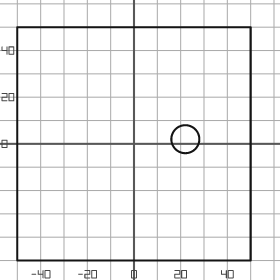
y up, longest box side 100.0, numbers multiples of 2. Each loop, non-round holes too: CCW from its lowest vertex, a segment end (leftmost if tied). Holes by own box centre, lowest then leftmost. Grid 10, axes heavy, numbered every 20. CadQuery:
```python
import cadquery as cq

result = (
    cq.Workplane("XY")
    .moveTo(-50.0, -50.0)
    .lineTo(50.0, -50.0)
    .lineTo(50.0, 50.0)
    .lineTo(-50.0, 50.0)
    .close()
    .moveTo(22.0, 2.0)
    .circle(6.0)
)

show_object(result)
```